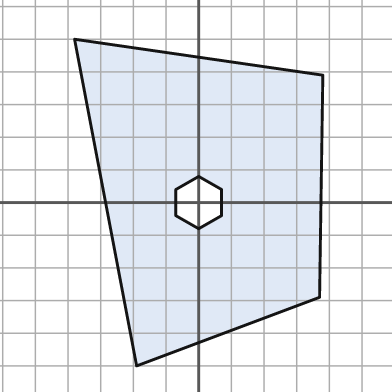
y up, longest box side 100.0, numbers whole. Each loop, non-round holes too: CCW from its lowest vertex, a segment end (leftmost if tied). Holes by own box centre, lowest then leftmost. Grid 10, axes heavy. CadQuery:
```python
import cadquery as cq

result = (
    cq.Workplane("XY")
    .moveTo(-19.0, -50.0)
    .lineTo(37.0, -29.0)
    .lineTo(38.0, 39.0)
    .lineTo(-38.0, 50.0)
    .close()
    .moveTo(0.0, -8.0)
    .lineTo(7.0, -4.0)
    .lineTo(7.0, 4.0)
    .lineTo(0.0, 8.0)
    .lineTo(-7.0, 4.0)
    .lineTo(-7.0, -4.0)
    .close()
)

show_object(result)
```